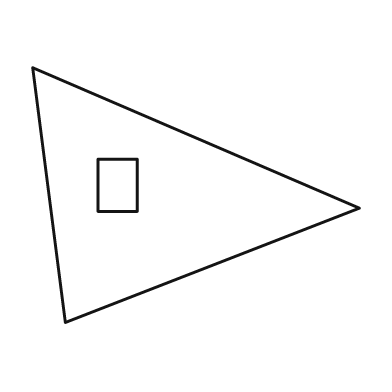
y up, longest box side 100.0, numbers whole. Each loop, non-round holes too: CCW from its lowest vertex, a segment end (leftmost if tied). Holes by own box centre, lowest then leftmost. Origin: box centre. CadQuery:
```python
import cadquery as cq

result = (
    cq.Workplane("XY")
    .moveTo(-40.0, -39.0)
    .lineTo(50.0, -4.0)
    .lineTo(-50.0, 39.0)
    .close()
    .moveTo(-30.0, -5.0)
    .lineTo(-18.0, -5.0)
    .lineTo(-18.0, 11.0)
    .lineTo(-30.0, 11.0)
    .close()
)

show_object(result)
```